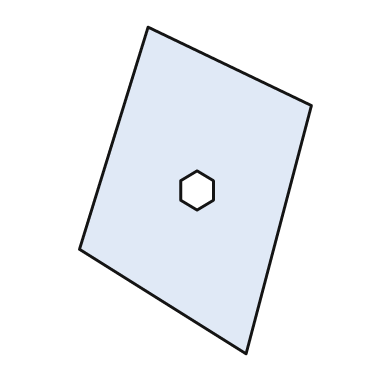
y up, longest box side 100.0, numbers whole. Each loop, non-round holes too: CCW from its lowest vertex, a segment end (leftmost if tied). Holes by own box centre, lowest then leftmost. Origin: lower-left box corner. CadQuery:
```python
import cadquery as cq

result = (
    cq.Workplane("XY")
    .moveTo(51.0, 0.0)
    .lineTo(71.0, 76.0)
    .lineTo(21.0, 100.0)
    .lineTo(0.0, 32.0)
    .close()
    .moveTo(36.0, 44.0)
    .lineTo(41.0, 47.0)
    .lineTo(41.0, 53.0)
    .lineTo(36.0, 56.0)
    .lineTo(31.0, 53.0)
    .lineTo(31.0, 47.0)
    .close()
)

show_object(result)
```